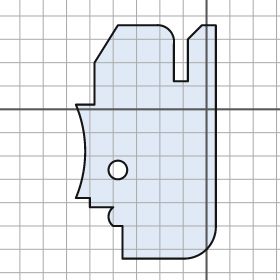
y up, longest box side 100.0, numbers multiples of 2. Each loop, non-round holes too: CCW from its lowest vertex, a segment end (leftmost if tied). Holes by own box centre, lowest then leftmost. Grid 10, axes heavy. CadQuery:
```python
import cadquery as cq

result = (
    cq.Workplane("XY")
    .moveTo(-36.0, -64.0)
    .lineTo(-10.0, -64.0)
    .threePointArc((0.0, -60.0), (4.0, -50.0))
    .lineTo(4.0, 36.0)
    .lineTo(-2.0, 36.0)
    .lineTo(-8.0, 30.0)
    .lineTo(-8.0, 12.0)
    .lineTo(-14.0, 12.0)
    .lineTo(-14.0, 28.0)
    .threePointArc((-16.0, 34.0), (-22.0, 36.0))
    .lineTo(-38.0, 36.0)
    .lineTo(-48.0, 20.0)
    .lineTo(-48.0, 2.0)
    .lineTo(-56.0, 2.0)
    .threePointArc((-52.0, -18.0), (-56.0, -38.0))
    .lineTo(-50.0, -38.0)
    .lineTo(-50.0, -42.0)
    .lineTo(-40.0, -42.0)
    .threePointArc((-42.0, -46.0), (-40.0, -50.0))
    .lineTo(-36.0, -50.0)
    .close()
    .moveTo(-38.0, -26.0)
    .circle(4.0)
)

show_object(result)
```